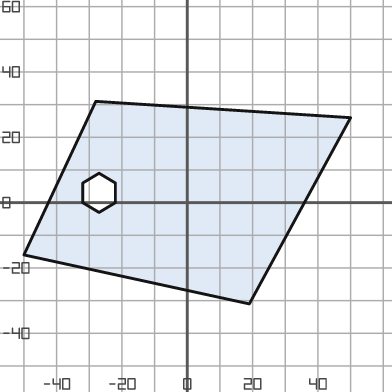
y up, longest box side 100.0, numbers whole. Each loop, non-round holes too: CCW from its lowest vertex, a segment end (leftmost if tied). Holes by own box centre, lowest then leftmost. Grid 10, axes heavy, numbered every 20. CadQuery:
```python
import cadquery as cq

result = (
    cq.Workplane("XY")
    .moveTo(19.0, -31.0)
    .lineTo(50.0, 26.0)
    .lineTo(-28.0, 31.0)
    .lineTo(-50.0, -16.0)
    .close()
    .moveTo(-27.0, -3.0)
    .lineTo(-22.0, 0.0)
    .lineTo(-22.0, 6.0)
    .lineTo(-27.0, 9.0)
    .lineTo(-32.0, 6.0)
    .lineTo(-32.0, 0.0)
    .close()
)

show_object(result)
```